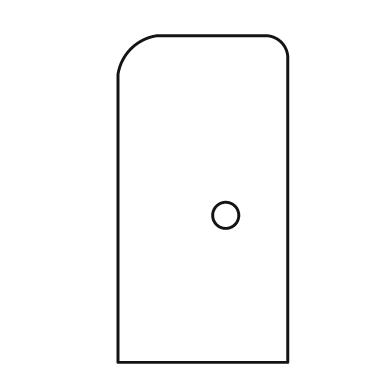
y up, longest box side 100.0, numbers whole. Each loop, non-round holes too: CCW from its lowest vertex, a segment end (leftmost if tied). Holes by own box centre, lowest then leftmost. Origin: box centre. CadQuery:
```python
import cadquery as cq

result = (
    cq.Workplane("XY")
    .moveTo(-26.0, -50.0)
    .lineTo(26.0, -50.0)
    .lineTo(26.0, 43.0)
    .threePointArc((24.0, 48.0), (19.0, 50.0))
    .lineTo(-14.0, 50.0)
    .threePointArc((-22.0, 46.0), (-26.0, 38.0))
    .close()
    .moveTo(7.0, -5.0)
    .circle(4.0)
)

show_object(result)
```